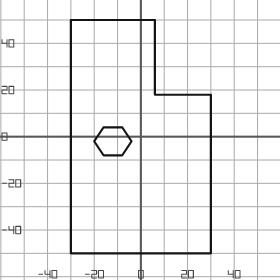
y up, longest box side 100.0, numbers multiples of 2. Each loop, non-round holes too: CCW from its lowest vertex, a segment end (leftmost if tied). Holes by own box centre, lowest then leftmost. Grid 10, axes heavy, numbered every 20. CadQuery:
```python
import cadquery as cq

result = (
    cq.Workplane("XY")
    .moveTo(-30.0, -50.0)
    .lineTo(30.0, -50.0)
    .lineTo(30.0, 18.0)
    .lineTo(6.0, 18.0)
    .lineTo(6.0, 50.0)
    .lineTo(-30.0, 50.0)
    .close()
    .moveTo(-16.0, -8.0)
    .lineTo(-8.0, -8.0)
    .lineTo(-4.0, -2.0)
    .lineTo(-8.0, 4.0)
    .lineTo(-16.0, 4.0)
    .lineTo(-20.0, -2.0)
    .close()
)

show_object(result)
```